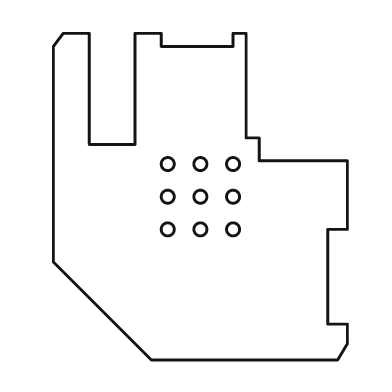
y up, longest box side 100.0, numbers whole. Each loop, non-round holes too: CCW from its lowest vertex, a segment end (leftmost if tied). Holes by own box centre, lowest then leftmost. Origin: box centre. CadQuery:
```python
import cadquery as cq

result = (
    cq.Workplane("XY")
    .moveTo(-15.0, -50.0)
    .lineTo(42.0, -50.0)
    .lineTo(45.0, -45.0)
    .lineTo(45.0, -39.0)
    .lineTo(39.0, -39.0)
    .lineTo(39.0, -10.0)
    .lineTo(45.0, -10.0)
    .lineTo(45.0, 11.0)
    .lineTo(18.0, 11.0)
    .lineTo(18.0, 18.0)
    .lineTo(14.0, 18.0)
    .lineTo(14.0, 50.0)
    .lineTo(10.0, 50.0)
    .lineTo(10.0, 46.0)
    .lineTo(-12.0, 46.0)
    .lineTo(-12.0, 50.0)
    .lineTo(-20.0, 50.0)
    .lineTo(-20.0, 16.0)
    .lineTo(-34.0, 16.0)
    .lineTo(-34.0, 50.0)
    .lineTo(-42.0, 50.0)
    .lineTo(-45.0, 46.0)
    .lineTo(-45.0, -20.0)
    .close()
    .moveTo(-10.0, -10.0)
    .circle(2.0)
    .moveTo(0.0, -10.0)
    .circle(2.0)
    .moveTo(10.0, -10.0)
    .circle(2.0)
    .moveTo(-10.0, 0.0)
    .circle(2.0)
    .moveTo(0.0, 0.0)
    .circle(2.0)
    .moveTo(10.0, 0.0)
    .circle(2.0)
    .moveTo(-10.0, 10.0)
    .circle(2.0)
    .moveTo(0.0, 10.0)
    .circle(2.0)
    .moveTo(10.0, 10.0)
    .circle(2.0)
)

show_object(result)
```